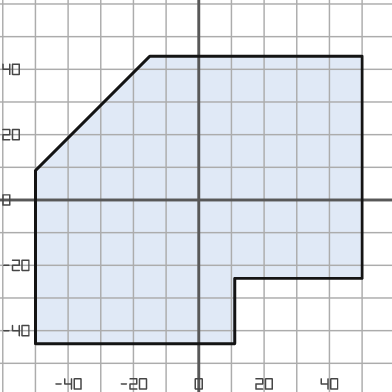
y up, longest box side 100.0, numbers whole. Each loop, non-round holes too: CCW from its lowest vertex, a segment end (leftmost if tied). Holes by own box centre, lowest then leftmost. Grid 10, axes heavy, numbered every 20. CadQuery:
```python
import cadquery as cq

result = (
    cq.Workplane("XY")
    .moveTo(-50.0, -44.0)
    .lineTo(11.0, -44.0)
    .lineTo(11.0, -24.0)
    .lineTo(50.0, -24.0)
    .lineTo(50.0, 44.0)
    .lineTo(-15.0, 44.0)
    .lineTo(-50.0, 9.0)
    .close()
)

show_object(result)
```